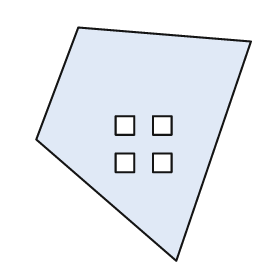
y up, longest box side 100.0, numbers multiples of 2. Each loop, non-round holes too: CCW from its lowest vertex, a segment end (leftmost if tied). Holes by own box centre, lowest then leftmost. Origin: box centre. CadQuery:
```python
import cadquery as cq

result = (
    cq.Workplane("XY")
    .moveTo(14.0, -50.0)
    .lineTo(46.0, 44.0)
    .lineTo(-28.0, 50.0)
    .lineTo(-46.0, 2.0)
    .close()
    .moveTo(-12.0, -12.0)
    .lineTo(-4.0, -12.0)
    .lineTo(-4.0, -4.0)
    .lineTo(-12.0, -4.0)
    .close()
    .moveTo(4.0, -12.0)
    .lineTo(12.0, -12.0)
    .lineTo(12.0, -4.0)
    .lineTo(4.0, -4.0)
    .close()
    .moveTo(-12.0, 4.0)
    .lineTo(-4.0, 4.0)
    .lineTo(-4.0, 12.0)
    .lineTo(-12.0, 12.0)
    .close()
    .moveTo(4.0, 4.0)
    .lineTo(12.0, 4.0)
    .lineTo(12.0, 12.0)
    .lineTo(4.0, 12.0)
    .close()
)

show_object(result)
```